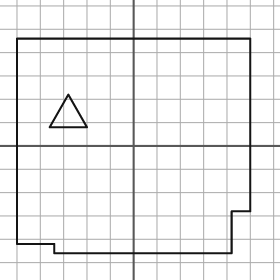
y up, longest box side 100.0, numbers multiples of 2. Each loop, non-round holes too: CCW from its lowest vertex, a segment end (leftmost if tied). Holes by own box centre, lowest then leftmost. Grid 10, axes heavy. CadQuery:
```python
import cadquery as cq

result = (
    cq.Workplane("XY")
    .moveTo(-34.0, -46.0)
    .lineTo(42.0, -46.0)
    .lineTo(42.0, -28.0)
    .lineTo(50.0, -28.0)
    .lineTo(50.0, 46.0)
    .lineTo(-50.0, 46.0)
    .lineTo(-50.0, -42.0)
    .lineTo(-34.0, -42.0)
    .close()
    .moveTo(-36.0, 8.0)
    .lineTo(-20.0, 8.0)
    .lineTo(-28.0, 22.0)
    .close()
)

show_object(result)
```